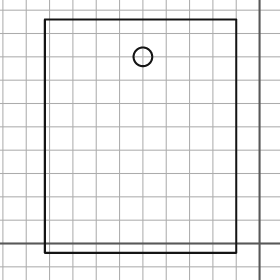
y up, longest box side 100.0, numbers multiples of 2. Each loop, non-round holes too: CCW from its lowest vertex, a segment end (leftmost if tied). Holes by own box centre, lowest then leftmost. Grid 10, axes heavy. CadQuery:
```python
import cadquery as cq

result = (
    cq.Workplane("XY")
    .moveTo(-92.0, -4.0)
    .lineTo(-10.0, -4.0)
    .lineTo(-10.0, 96.0)
    .lineTo(-92.0, 96.0)
    .close()
    .moveTo(-50.0, 80.0)
    .circle(4.0)
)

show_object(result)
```